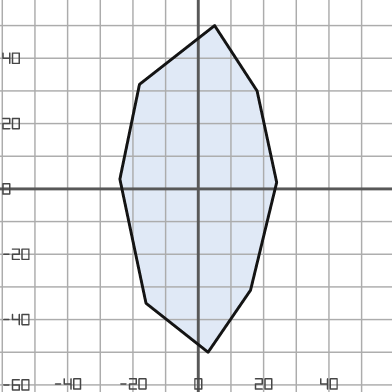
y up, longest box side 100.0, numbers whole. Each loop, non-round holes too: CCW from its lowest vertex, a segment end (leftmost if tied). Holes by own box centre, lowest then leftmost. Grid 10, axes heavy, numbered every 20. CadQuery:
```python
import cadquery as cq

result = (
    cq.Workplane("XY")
    .moveTo(3.0, -50.0)
    .lineTo(16.0, -31.0)
    .lineTo(24.0, 2.0)
    .lineTo(18.0, 30.0)
    .lineTo(5.0, 50.0)
    .lineTo(-18.0, 32.0)
    .lineTo(-24.0, 3.0)
    .lineTo(-16.0, -35.0)
    .close()
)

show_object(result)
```